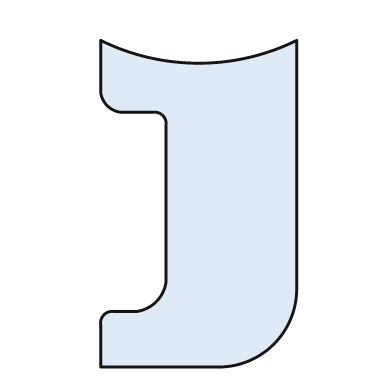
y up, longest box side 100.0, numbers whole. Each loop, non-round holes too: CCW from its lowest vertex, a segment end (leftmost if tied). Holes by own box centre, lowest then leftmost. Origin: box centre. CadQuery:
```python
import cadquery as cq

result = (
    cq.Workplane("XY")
    .moveTo(-30.0, -50.0)
    .lineTo(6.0, -50.0)
    .threePointArc((23.0, -43.0), (30.0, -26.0))
    .lineTo(30.0, 50.0)
    .threePointArc((0.0, 43.0), (-30.0, 50.0))
    .lineTo(-30.0, 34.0)
    .threePointArc((-28.0, 30.0), (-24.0, 28.0))
    .lineTo(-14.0, 28.0)
    .threePointArc((-11.0, 27.0), (-10.0, 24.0))
    .lineTo(-10.0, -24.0)
    .threePointArc((-13.0, -30.0), (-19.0, -33.0))
    .lineTo(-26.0, -33.0)
    .threePointArc((-29.0, -34.0), (-30.0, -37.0))
    .close()
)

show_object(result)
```